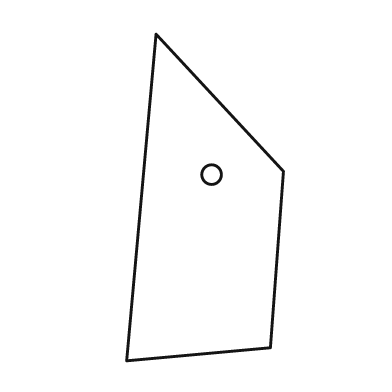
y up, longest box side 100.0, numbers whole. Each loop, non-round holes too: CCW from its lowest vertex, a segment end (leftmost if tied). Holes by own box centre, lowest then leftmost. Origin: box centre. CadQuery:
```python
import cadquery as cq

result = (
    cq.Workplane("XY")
    .moveTo(-24.0, -50.0)
    .lineTo(20.0, -46.0)
    .lineTo(24.0, 8.0)
    .lineTo(-15.0, 50.0)
    .close()
    .moveTo(2.0, 7.0)
    .circle(3.0)
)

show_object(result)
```